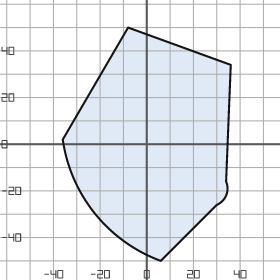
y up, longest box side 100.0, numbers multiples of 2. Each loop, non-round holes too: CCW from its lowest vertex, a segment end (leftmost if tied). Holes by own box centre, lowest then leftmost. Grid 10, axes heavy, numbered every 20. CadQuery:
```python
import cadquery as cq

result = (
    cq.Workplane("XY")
    .moveTo(6.0, -50.0)
    .lineTo(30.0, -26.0)
    .threePointArc((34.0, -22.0), (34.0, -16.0))
    .lineTo(36.0, 34.0)
    .lineTo(-8.0, 50.0)
    .lineTo(-36.0, 2.0)
    .threePointArc((-22.0, -30.0), (6.0, -50.0))
    .close()
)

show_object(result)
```